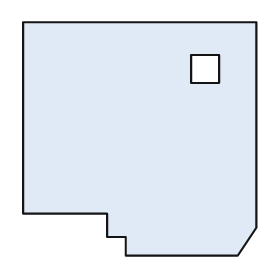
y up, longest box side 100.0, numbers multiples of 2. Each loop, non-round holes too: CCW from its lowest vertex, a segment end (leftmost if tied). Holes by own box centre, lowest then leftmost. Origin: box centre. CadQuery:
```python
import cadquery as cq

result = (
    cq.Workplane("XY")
    .moveTo(-6.0, -50.0)
    .lineTo(42.0, -50.0)
    .lineTo(50.0, -38.0)
    .lineTo(50.0, 50.0)
    .lineTo(-50.0, 50.0)
    .lineTo(-50.0, -32.0)
    .lineTo(-14.0, -32.0)
    .lineTo(-14.0, -42.0)
    .lineTo(-6.0, -42.0)
    .close()
    .moveTo(22.0, 24.0)
    .lineTo(34.0, 24.0)
    .lineTo(34.0, 36.0)
    .lineTo(22.0, 36.0)
    .close()
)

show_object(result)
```